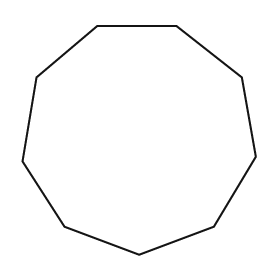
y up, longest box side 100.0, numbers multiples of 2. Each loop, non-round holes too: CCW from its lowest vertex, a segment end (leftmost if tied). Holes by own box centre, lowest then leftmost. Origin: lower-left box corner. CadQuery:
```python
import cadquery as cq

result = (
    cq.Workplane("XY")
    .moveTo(50.0, 0.0)
    .lineTo(82.0, 12.0)
    .lineTo(100.0, 42.0)
    .lineTo(94.0, 76.0)
    .lineTo(66.0, 98.0)
    .lineTo(32.0, 98.0)
    .lineTo(6.0, 76.0)
    .lineTo(0.0, 40.0)
    .lineTo(18.0, 12.0)
    .close()
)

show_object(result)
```